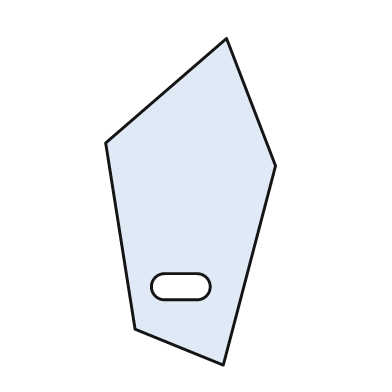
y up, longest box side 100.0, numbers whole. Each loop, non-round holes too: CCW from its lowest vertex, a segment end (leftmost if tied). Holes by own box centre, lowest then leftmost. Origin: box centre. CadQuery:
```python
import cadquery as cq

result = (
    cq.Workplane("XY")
    .moveTo(10.0, -50.0)
    .lineTo(26.0, 11.0)
    .lineTo(11.0, 50.0)
    .lineTo(-26.0, 18.0)
    .lineTo(-17.0, -39.0)
    .close()
    .moveTo(-8.0, -30.0)
    .lineTo(2.0, -30.0)
    .threePointArc((6.0, -26.0), (2.0, -22.0))
    .lineTo(-8.0, -22.0)
    .threePointArc((-12.0, -26.0), (-8.0, -30.0))
    .close()
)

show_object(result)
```